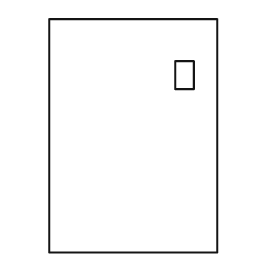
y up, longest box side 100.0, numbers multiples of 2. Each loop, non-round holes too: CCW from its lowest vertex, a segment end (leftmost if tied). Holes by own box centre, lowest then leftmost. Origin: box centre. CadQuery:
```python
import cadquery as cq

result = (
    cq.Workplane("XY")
    .moveTo(-36.0, -50.0)
    .lineTo(36.0, -50.0)
    .lineTo(36.0, 50.0)
    .lineTo(-36.0, 50.0)
    .close()
    .moveTo(18.0, 20.0)
    .lineTo(26.0, 20.0)
    .lineTo(26.0, 32.0)
    .lineTo(18.0, 32.0)
    .close()
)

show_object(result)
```